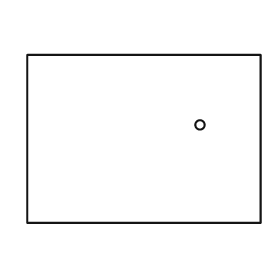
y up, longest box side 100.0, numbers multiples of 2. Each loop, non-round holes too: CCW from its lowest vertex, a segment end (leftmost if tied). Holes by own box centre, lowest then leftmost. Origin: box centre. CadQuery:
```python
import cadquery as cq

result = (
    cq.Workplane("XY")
    .moveTo(-50.0, -36.0)
    .lineTo(50.0, -36.0)
    .lineTo(50.0, 36.0)
    .lineTo(-50.0, 36.0)
    .close()
    .moveTo(24.0, 6.0)
    .circle(2.0)
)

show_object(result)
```